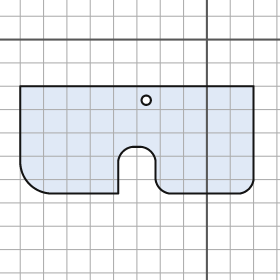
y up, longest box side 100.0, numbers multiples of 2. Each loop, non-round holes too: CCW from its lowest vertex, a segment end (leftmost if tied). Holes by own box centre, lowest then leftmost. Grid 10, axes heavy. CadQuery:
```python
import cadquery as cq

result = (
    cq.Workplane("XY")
    .moveTo(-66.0, -66.0)
    .lineTo(-38.0, -66.0)
    .lineTo(-38.0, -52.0)
    .threePointArc((-36.0, -48.0), (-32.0, -46.0))
    .lineTo(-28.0, -46.0)
    .threePointArc((-24.0, -48.0), (-22.0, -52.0))
    .lineTo(-22.0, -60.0)
    .threePointArc((-20.0, -64.0), (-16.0, -66.0))
    .lineTo(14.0, -66.0)
    .threePointArc((18.0, -64.0), (20.0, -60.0))
    .lineTo(20.0, -20.0)
    .lineTo(-80.0, -20.0)
    .lineTo(-80.0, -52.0)
    .threePointArc((-76.0, -62.0), (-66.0, -66.0))
    .close()
    .moveTo(-26.0, -26.0)
    .circle(2.0)
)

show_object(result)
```